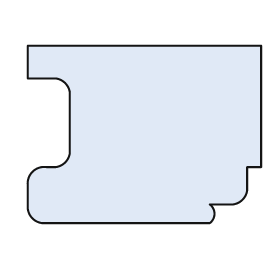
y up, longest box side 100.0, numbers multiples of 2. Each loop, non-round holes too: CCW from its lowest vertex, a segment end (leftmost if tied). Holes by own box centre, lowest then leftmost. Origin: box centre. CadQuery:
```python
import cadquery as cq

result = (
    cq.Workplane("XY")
    .moveTo(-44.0, -38.0)
    .lineTo(28.0, -38.0)
    .threePointArc((30.0, -34.0), (28.0, -30.0))
    .lineTo(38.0, -30.0)
    .threePointArc((42.0, -28.0), (44.0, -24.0))
    .lineTo(44.0, -14.0)
    .lineTo(50.0, -14.0)
    .lineTo(50.0, 38.0)
    .lineTo(-50.0, 38.0)
    .lineTo(-50.0, 24.0)
    .lineTo(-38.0, 24.0)
    .threePointArc((-34.0, 22.0), (-32.0, 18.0))
    .lineTo(-32.0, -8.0)
    .threePointArc((-34.0, -12.0), (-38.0, -14.0))
    .lineTo(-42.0, -14.0)
    .threePointArc((-48.0, -16.0), (-50.0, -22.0))
    .lineTo(-50.0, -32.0)
    .threePointArc((-48.0, -36.0), (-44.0, -38.0))
    .close()
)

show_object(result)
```